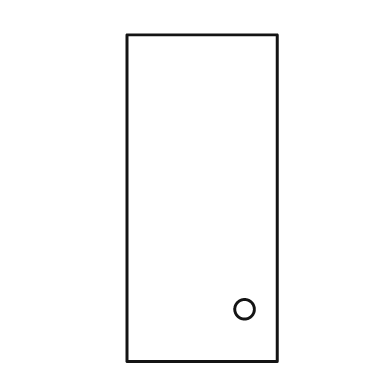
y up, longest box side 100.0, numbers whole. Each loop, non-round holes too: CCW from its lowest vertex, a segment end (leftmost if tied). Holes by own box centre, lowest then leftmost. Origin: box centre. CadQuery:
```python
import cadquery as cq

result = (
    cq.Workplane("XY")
    .moveTo(-23.0, -50.0)
    .lineTo(23.0, -50.0)
    .lineTo(23.0, 50.0)
    .lineTo(-23.0, 50.0)
    .close()
    .moveTo(13.0, -34.0)
    .circle(3.0)
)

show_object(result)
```